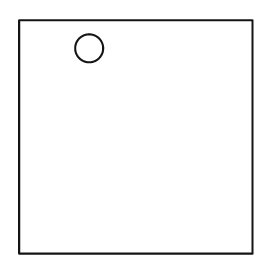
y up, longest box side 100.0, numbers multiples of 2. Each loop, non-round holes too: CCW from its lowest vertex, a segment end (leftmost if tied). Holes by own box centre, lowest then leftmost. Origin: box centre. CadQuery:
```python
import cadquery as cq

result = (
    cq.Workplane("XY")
    .moveTo(-50.0, -50.0)
    .lineTo(50.0, -50.0)
    .lineTo(50.0, 50.0)
    .lineTo(-50.0, 50.0)
    .close()
    .moveTo(-20.0, 38.0)
    .circle(6.0)
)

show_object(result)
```